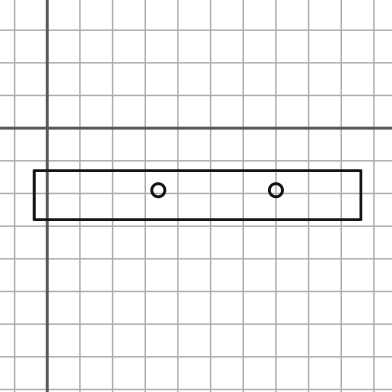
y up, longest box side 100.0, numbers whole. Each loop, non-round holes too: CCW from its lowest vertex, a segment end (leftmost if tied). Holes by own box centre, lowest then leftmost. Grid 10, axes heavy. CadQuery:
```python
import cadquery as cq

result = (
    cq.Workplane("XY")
    .moveTo(-4.0, -28.0)
    .lineTo(96.0, -28.0)
    .lineTo(96.0, -13.0)
    .lineTo(-4.0, -13.0)
    .close()
    .moveTo(34.0, -19.0)
    .circle(2.0)
    .moveTo(70.0, -19.0)
    .circle(2.0)
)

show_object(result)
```